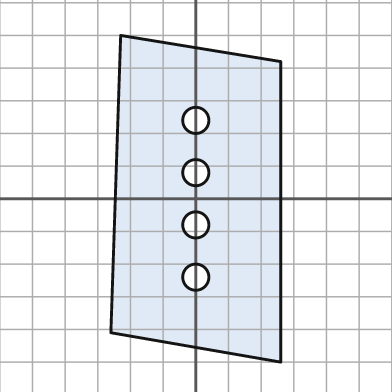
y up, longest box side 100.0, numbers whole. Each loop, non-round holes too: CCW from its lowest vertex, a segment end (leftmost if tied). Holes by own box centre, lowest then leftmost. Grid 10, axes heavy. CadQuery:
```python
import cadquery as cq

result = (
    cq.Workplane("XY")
    .moveTo(26.0, -50.0)
    .lineTo(26.0, 42.0)
    .lineTo(-23.0, 50.0)
    .lineTo(-26.0, -41.0)
    .close()
    .moveTo(0.0, -24.0)
    .circle(4.0)
    .moveTo(0.0, -8.0)
    .circle(4.0)
    .moveTo(0.0, 8.0)
    .circle(4.0)
    .moveTo(0.0, 24.0)
    .circle(4.0)
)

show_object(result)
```